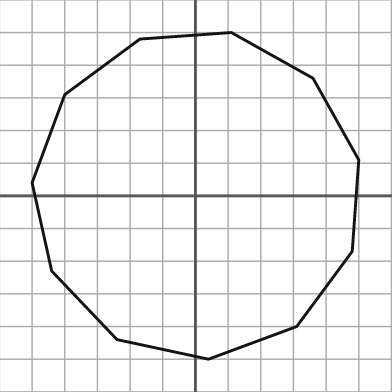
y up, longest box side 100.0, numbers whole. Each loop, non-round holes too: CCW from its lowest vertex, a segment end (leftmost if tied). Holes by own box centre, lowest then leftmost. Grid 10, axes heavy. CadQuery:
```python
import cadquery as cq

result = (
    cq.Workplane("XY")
    .moveTo(4.0, -50.0)
    .lineTo(31.0, -40.0)
    .lineTo(48.0, -17.0)
    .lineTo(50.0, 11.0)
    .lineTo(36.0, 36.0)
    .lineTo(11.0, 50.0)
    .lineTo(-17.0, 48.0)
    .lineTo(-40.0, 31.0)
    .lineTo(-50.0, 4.0)
    .lineTo(-44.0, -23.0)
    .lineTo(-24.0, -44.0)
    .close()
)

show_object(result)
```